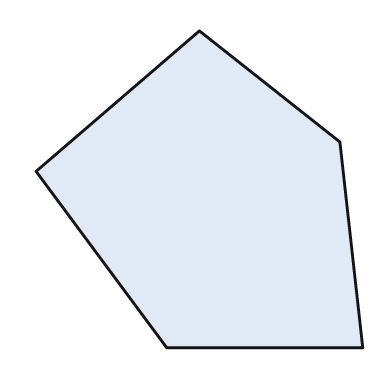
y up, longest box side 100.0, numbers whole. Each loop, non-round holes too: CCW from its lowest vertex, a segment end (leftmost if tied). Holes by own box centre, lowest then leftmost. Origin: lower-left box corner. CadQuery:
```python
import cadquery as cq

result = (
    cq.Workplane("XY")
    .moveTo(40.0, 0.0)
    .lineTo(100.0, 0.0)
    .lineTo(93.0, 63.0)
    .lineTo(50.0, 97.0)
    .lineTo(0.0, 54.0)
    .close()
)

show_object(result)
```